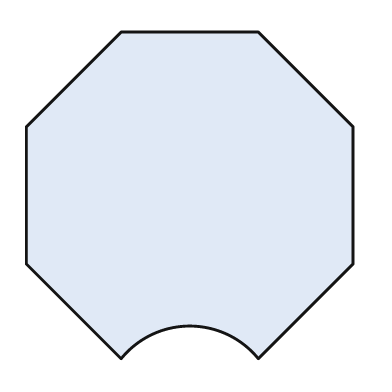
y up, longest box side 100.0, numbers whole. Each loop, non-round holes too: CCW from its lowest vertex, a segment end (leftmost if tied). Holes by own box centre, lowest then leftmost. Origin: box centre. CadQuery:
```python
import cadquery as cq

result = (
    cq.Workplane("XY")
    .moveTo(-21.0, -50.0)
    .threePointArc((0.0, -40.0), (21.0, -50.0))
    .lineTo(50.0, -21.0)
    .lineTo(50.0, 21.0)
    .lineTo(21.0, 50.0)
    .lineTo(-21.0, 50.0)
    .lineTo(-50.0, 21.0)
    .lineTo(-50.0, -21.0)
    .close()
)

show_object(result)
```